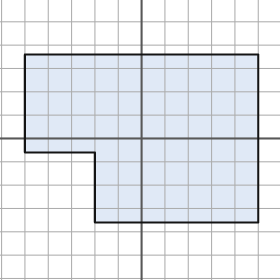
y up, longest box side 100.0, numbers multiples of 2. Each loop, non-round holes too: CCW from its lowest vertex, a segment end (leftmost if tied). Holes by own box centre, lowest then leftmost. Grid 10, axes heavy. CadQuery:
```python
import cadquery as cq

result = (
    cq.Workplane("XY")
    .moveTo(-20.0, -36.0)
    .lineTo(50.0, -36.0)
    .lineTo(50.0, 36.0)
    .lineTo(-50.0, 36.0)
    .lineTo(-50.0, -6.0)
    .lineTo(-20.0, -6.0)
    .close()
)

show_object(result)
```